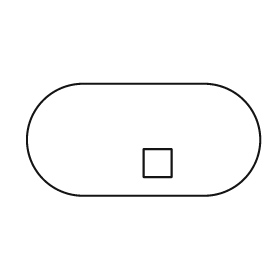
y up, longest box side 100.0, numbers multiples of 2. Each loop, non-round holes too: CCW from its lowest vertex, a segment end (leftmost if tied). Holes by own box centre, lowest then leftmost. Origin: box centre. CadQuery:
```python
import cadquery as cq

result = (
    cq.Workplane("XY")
    .moveTo(-26.0, -24.0)
    .lineTo(26.0, -24.0)
    .threePointArc((50.0, 0.0), (26.0, 24.0))
    .lineTo(-26.0, 24.0)
    .threePointArc((-50.0, 0.0), (-26.0, -24.0))
    .close()
    .moveTo(0.0, -16.0)
    .lineTo(12.0, -16.0)
    .lineTo(12.0, -4.0)
    .lineTo(0.0, -4.0)
    .close()
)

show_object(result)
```